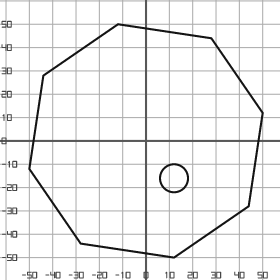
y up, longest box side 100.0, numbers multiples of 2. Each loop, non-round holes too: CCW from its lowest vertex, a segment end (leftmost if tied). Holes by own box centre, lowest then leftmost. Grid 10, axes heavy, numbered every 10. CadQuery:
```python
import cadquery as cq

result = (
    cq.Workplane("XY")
    .moveTo(12.0, -50.0)
    .lineTo(44.0, -28.0)
    .lineTo(50.0, 12.0)
    .lineTo(28.0, 44.0)
    .lineTo(-12.0, 50.0)
    .lineTo(-44.0, 28.0)
    .lineTo(-50.0, -12.0)
    .lineTo(-28.0, -44.0)
    .close()
    .moveTo(12.0, -16.0)
    .circle(6.0)
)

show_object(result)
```